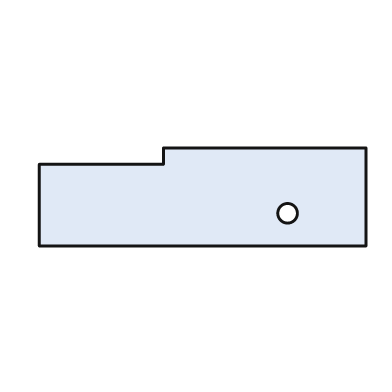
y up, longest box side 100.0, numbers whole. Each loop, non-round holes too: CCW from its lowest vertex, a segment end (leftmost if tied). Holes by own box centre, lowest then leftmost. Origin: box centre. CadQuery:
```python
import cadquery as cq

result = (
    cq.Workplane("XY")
    .moveTo(-50.0, -15.0)
    .lineTo(50.0, -15.0)
    .lineTo(50.0, 15.0)
    .lineTo(-12.0, 15.0)
    .lineTo(-12.0, 10.0)
    .lineTo(-50.0, 10.0)
    .close()
    .moveTo(26.0, -5.0)
    .circle(3.0)
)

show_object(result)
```